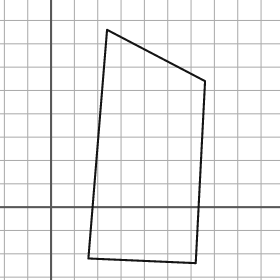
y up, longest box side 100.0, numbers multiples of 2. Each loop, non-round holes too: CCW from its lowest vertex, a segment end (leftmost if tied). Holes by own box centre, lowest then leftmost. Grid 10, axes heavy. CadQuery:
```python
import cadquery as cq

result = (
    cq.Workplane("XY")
    .moveTo(62.0, -24.0)
    .lineTo(66.0, 54.0)
    .lineTo(24.0, 76.0)
    .lineTo(16.0, -22.0)
    .close()
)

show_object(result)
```